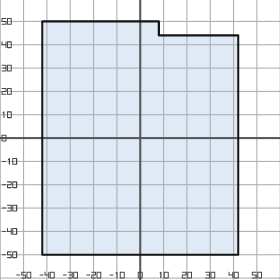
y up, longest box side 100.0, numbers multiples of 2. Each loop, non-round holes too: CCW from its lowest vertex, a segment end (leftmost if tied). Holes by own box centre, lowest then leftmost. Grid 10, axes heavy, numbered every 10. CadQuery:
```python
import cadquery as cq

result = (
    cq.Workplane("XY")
    .moveTo(-42.0, -50.0)
    .lineTo(42.0, -50.0)
    .lineTo(42.0, 44.0)
    .lineTo(8.0, 44.0)
    .lineTo(8.0, 50.0)
    .lineTo(-42.0, 50.0)
    .close()
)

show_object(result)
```